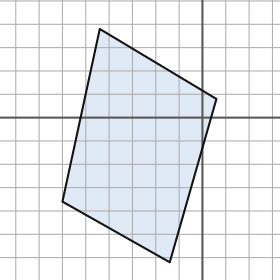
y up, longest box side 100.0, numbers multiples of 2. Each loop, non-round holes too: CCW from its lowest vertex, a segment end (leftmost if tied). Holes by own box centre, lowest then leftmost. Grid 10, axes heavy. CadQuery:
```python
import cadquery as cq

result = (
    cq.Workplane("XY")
    .moveTo(-14.0, -62.0)
    .lineTo(6.0, 8.0)
    .lineTo(-44.0, 38.0)
    .lineTo(-60.0, -36.0)
    .close()
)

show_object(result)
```